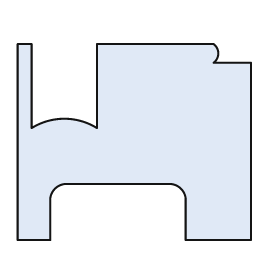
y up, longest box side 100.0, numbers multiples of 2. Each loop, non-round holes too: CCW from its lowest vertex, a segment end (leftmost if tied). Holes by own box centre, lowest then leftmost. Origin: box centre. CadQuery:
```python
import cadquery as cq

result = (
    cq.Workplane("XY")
    .moveTo(-50.0, -42.0)
    .lineTo(-36.0, -42.0)
    .lineTo(-36.0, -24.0)
    .threePointArc((-34.0, -20.0), (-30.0, -18.0))
    .lineTo(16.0, -18.0)
    .threePointArc((20.0, -20.0), (22.0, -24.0))
    .lineTo(22.0, -42.0)
    .lineTo(50.0, -42.0)
    .lineTo(50.0, 34.0)
    .lineTo(34.0, 34.0)
    .threePointArc((36.0, 38.0), (34.0, 42.0))
    .lineTo(-16.0, 42.0)
    .lineTo(-16.0, 6.0)
    .threePointArc((-30.0, 10.0), (-44.0, 6.0))
    .lineTo(-44.0, 42.0)
    .lineTo(-50.0, 42.0)
    .close()
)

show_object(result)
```